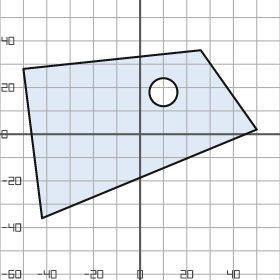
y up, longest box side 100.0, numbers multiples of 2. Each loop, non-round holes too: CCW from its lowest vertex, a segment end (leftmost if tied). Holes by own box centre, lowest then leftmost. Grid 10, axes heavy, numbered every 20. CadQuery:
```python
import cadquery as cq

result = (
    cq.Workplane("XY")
    .moveTo(-42.0, -36.0)
    .lineTo(50.0, 2.0)
    .lineTo(26.0, 36.0)
    .lineTo(-50.0, 28.0)
    .close()
    .moveTo(10.0, 18.0)
    .circle(6.0)
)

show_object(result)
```